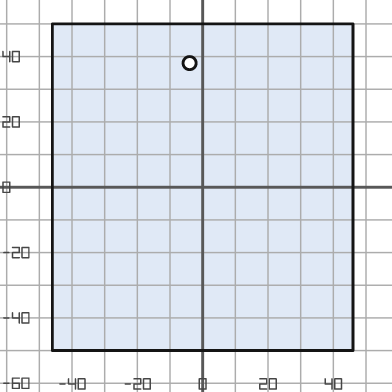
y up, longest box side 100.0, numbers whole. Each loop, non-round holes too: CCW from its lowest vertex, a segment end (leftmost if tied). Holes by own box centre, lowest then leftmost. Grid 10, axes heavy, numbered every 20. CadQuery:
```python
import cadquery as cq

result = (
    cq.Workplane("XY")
    .moveTo(-46.0, -50.0)
    .lineTo(46.0, -50.0)
    .lineTo(46.0, 50.0)
    .lineTo(-46.0, 50.0)
    .close()
    .moveTo(-4.0, 38.0)
    .circle(2.0)
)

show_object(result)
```